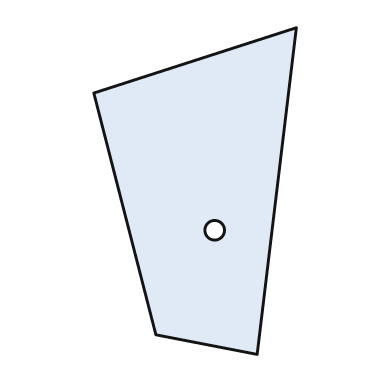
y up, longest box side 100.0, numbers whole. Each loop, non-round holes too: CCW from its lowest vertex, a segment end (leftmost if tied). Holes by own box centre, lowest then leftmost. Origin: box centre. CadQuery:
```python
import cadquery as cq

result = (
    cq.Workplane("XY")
    .moveTo(19.0, -50.0)
    .lineTo(31.0, 50.0)
    .lineTo(-31.0, 30.0)
    .lineTo(-12.0, -44.0)
    .close()
    .moveTo(6.0, -12.0)
    .circle(3.0)
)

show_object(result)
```